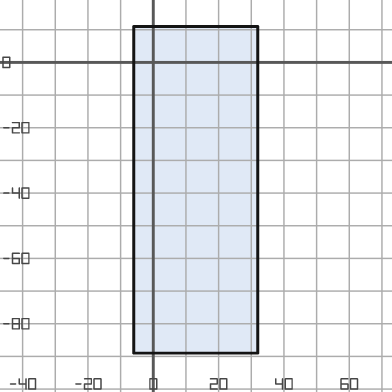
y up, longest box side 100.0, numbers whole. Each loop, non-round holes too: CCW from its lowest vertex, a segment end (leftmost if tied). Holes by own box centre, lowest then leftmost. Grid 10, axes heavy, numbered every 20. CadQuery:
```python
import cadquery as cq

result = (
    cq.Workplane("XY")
    .moveTo(-6.0, -89.0)
    .lineTo(32.0, -89.0)
    .lineTo(32.0, 11.0)
    .lineTo(-6.0, 11.0)
    .close()
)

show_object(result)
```